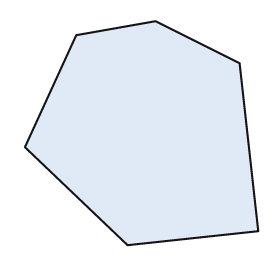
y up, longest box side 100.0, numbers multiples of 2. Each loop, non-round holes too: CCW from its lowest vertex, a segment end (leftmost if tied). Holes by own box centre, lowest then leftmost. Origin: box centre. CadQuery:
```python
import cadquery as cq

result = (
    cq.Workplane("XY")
    .moveTo(-6.0, -48.0)
    .lineTo(50.0, -42.0)
    .lineTo(42.0, 30.0)
    .lineTo(6.0, 48.0)
    .lineTo(-28.0, 42.0)
    .lineTo(-50.0, -6.0)
    .close()
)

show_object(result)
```